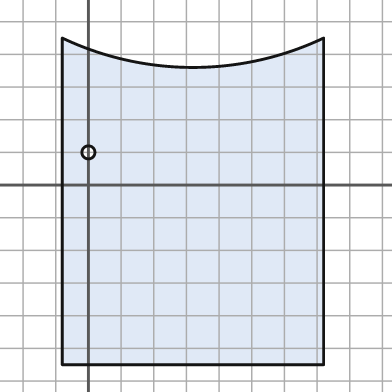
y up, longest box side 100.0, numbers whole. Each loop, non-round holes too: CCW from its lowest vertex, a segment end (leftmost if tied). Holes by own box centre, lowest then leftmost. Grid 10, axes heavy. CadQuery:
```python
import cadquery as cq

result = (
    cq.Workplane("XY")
    .moveTo(-8.0, -55.0)
    .lineTo(72.0, -55.0)
    .lineTo(72.0, 45.0)
    .threePointArc((32.0, 36.0), (-8.0, 45.0))
    .close()
    .moveTo(0.0, 10.0)
    .circle(2.0)
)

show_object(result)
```